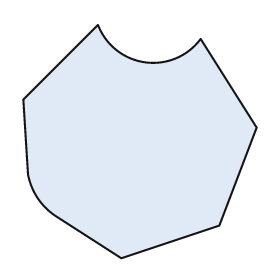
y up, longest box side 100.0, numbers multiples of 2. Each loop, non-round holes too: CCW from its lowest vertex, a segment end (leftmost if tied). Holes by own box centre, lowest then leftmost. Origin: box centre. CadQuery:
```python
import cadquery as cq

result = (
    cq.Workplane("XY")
    .moveTo(-8.0, -50.0)
    .lineTo(34.0, -36.0)
    .lineTo(50.0, 6.0)
    .lineTo(26.0, 44.0)
    .threePointArc((2.0, 34.0), (-18.0, 50.0))
    .lineTo(-50.0, 18.0)
    .lineTo(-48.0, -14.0)
    .threePointArc((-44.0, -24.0), (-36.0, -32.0))
    .close()
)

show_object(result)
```